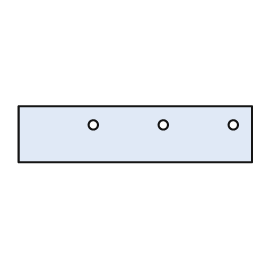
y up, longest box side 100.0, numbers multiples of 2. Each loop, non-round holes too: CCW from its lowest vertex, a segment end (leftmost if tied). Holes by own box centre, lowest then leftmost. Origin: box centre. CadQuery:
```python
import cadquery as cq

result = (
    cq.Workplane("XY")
    .moveTo(-50.0, -12.0)
    .lineTo(50.0, -12.0)
    .lineTo(50.0, 12.0)
    .lineTo(-50.0, 12.0)
    .close()
    .moveTo(-18.0, 4.0)
    .circle(2.0)
    .moveTo(12.0, 4.0)
    .circle(2.0)
    .moveTo(42.0, 4.0)
    .circle(2.0)
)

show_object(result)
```